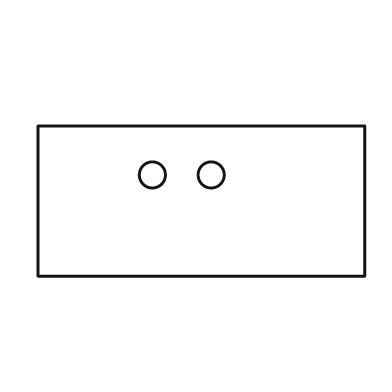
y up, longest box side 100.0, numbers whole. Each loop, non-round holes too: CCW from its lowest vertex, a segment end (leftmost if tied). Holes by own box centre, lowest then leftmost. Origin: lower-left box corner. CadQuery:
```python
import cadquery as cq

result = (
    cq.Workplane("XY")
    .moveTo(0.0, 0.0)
    .lineTo(100.0, 0.0)
    .lineTo(100.0, 46.0)
    .lineTo(0.0, 46.0)
    .close()
    .moveTo(35.0, 31.0)
    .circle(4.0)
    .moveTo(53.0, 31.0)
    .circle(4.0)
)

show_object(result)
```